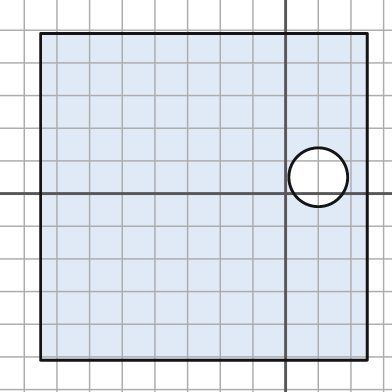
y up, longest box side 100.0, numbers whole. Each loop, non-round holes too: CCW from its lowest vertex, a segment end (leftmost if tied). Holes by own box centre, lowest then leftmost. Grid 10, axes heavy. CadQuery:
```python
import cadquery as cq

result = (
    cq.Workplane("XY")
    .moveTo(-75.0, -51.0)
    .lineTo(25.0, -51.0)
    .lineTo(25.0, 49.0)
    .lineTo(-75.0, 49.0)
    .close()
    .moveTo(10.0, 5.0)
    .circle(9.0)
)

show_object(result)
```